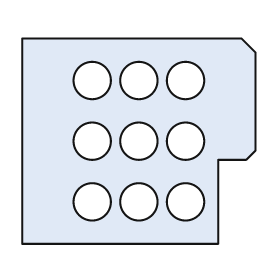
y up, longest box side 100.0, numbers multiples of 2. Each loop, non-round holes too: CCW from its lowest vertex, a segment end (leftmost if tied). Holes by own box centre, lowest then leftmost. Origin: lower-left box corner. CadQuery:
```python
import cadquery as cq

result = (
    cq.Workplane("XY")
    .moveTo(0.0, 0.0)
    .lineTo(84.0, 0.0)
    .lineTo(84.0, 36.0)
    .lineTo(96.0, 36.0)
    .lineTo(100.0, 40.0)
    .lineTo(100.0, 82.0)
    .lineTo(94.0, 88.0)
    .lineTo(0.0, 88.0)
    .close()
    .moveTo(30.0, 18.0)
    .circle(8.0)
    .moveTo(50.0, 18.0)
    .circle(8.0)
    .moveTo(70.0, 18.0)
    .circle(8.0)
    .moveTo(30.0, 44.0)
    .circle(8.0)
    .moveTo(50.0, 44.0)
    .circle(8.0)
    .moveTo(70.0, 44.0)
    .circle(8.0)
    .moveTo(30.0, 70.0)
    .circle(8.0)
    .moveTo(50.0, 70.0)
    .circle(8.0)
    .moveTo(70.0, 70.0)
    .circle(8.0)
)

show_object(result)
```